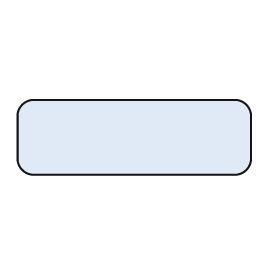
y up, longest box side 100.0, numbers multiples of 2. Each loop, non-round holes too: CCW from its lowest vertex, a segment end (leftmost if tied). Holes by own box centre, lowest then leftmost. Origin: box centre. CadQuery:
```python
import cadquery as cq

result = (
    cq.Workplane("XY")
    .moveTo(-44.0, -16.0)
    .lineTo(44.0, -16.0)
    .threePointArc((48.0, -14.0), (50.0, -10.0))
    .lineTo(50.0, 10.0)
    .threePointArc((48.0, 14.0), (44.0, 16.0))
    .lineTo(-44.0, 16.0)
    .threePointArc((-48.0, 14.0), (-50.0, 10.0))
    .lineTo(-50.0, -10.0)
    .threePointArc((-48.0, -14.0), (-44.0, -16.0))
    .close()
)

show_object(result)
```